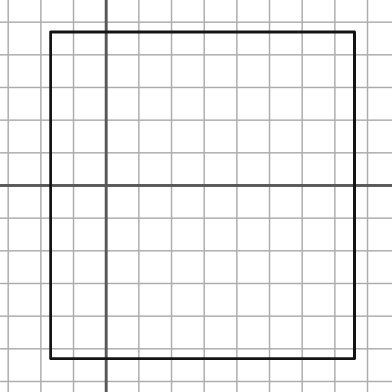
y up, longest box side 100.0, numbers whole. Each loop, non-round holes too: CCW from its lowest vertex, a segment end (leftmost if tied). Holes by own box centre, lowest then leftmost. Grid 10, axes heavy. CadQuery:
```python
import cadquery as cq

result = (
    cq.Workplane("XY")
    .moveTo(-17.0, -53.0)
    .lineTo(76.0, -53.0)
    .lineTo(76.0, 47.0)
    .lineTo(-17.0, 47.0)
    .close()
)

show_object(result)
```